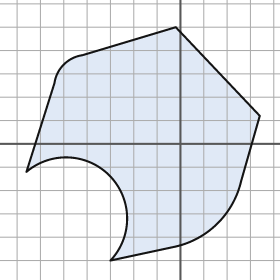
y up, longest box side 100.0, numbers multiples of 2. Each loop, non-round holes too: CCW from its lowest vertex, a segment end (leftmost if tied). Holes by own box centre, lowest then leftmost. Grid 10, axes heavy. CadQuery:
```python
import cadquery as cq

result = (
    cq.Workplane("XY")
    .moveTo(-30.0, -50.0)
    .lineTo(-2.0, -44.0)
    .threePointArc((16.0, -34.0), (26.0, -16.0))
    .lineTo(34.0, 12.0)
    .lineTo(-2.0, 50.0)
    .lineTo(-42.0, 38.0)
    .threePointArc((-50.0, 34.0), (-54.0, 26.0))
    .lineTo(-66.0, -12.0)
    .threePointArc((-30.0, -14.0), (-30.0, -50.0))
    .close()
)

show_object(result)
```